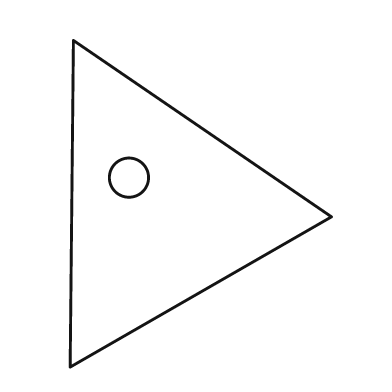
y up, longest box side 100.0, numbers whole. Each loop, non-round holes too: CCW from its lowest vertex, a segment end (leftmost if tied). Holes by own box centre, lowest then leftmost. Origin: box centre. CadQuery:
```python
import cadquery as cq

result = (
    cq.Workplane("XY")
    .moveTo(-40.0, -50.0)
    .lineTo(40.0, -4.0)
    .lineTo(-39.0, 50.0)
    .close()
    .moveTo(-22.0, 8.0)
    .circle(6.0)
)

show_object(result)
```